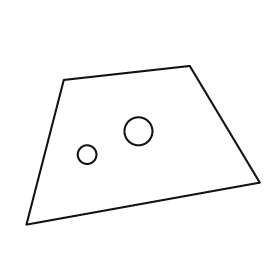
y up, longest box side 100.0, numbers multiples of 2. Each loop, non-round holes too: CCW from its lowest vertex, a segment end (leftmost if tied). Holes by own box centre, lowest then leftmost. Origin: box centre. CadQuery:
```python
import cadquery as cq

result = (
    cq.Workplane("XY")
    .moveTo(-50.0, -34.0)
    .lineTo(50.0, -16.0)
    .lineTo(20.0, 34.0)
    .lineTo(-34.0, 28.0)
    .close()
    .moveTo(-24.0, -4.0)
    .circle(4.0)
    .moveTo(-2.0, 6.0)
    .circle(6.0)
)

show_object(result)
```